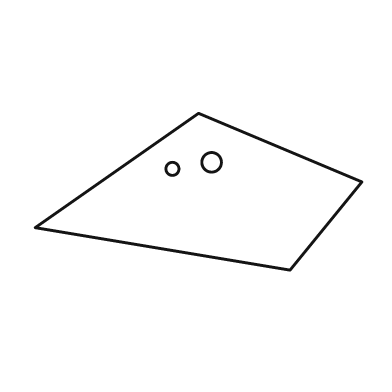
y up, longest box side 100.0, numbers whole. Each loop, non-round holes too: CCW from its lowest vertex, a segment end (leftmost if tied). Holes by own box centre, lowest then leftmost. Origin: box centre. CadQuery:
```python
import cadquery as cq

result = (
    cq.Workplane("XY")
    .moveTo(28.0, -24.0)
    .lineTo(50.0, 3.0)
    .lineTo(0.0, 24.0)
    .lineTo(-50.0, -11.0)
    .close()
    .moveTo(-8.0, 7.0)
    .circle(2.0)
    .moveTo(4.0, 9.0)
    .circle(3.0)
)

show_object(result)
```